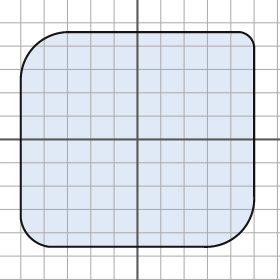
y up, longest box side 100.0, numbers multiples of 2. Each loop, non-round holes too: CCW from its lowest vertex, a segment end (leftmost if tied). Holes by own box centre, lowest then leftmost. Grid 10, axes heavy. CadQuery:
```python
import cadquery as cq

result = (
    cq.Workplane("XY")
    .moveTo(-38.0, -46.0)
    .lineTo(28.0, -46.0)
    .threePointArc((44.0, -40.0), (50.0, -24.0))
    .lineTo(50.0, 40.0)
    .threePointArc((48.0, 44.0), (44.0, 46.0))
    .lineTo(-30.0, 46.0)
    .threePointArc((-44.0, 40.0), (-50.0, 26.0))
    .lineTo(-50.0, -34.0)
    .threePointArc((-46.0, -42.0), (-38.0, -46.0))
    .close()
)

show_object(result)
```